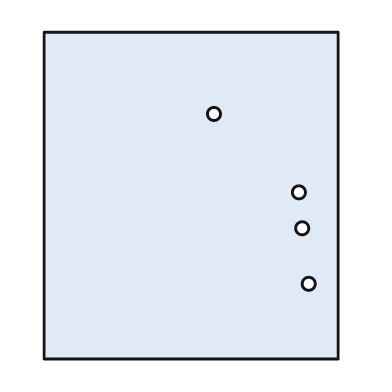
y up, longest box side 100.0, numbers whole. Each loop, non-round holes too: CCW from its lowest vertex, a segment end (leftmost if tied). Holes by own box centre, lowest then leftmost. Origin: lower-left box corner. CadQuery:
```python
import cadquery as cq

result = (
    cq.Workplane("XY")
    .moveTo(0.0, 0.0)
    .lineTo(90.0, 0.0)
    .lineTo(90.0, 100.0)
    .lineTo(0.0, 100.0)
    .close()
    .moveTo(81.0, 23.0)
    .circle(2.0)
    .moveTo(79.0, 40.0)
    .circle(2.0)
    .moveTo(78.0, 51.0)
    .circle(2.0)
    .moveTo(52.0, 75.0)
    .circle(2.0)
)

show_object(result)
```